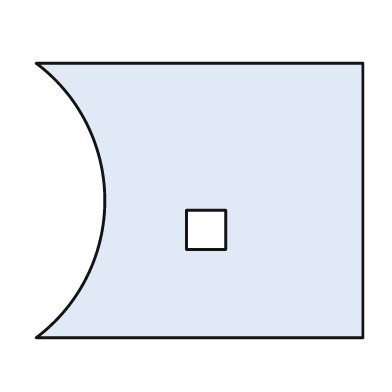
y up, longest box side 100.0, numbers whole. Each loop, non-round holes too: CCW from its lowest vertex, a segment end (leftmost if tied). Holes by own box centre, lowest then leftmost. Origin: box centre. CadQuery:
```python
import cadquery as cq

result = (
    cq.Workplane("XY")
    .moveTo(-50.0, -42.0)
    .lineTo(50.0, -42.0)
    .lineTo(50.0, 42.0)
    .lineTo(-50.0, 42.0)
    .threePointArc((-29.0, 0.0), (-50.0, -42.0))
    .close()
    .moveTo(-4.0, -15.0)
    .lineTo(8.0, -15.0)
    .lineTo(8.0, -3.0)
    .lineTo(-4.0, -3.0)
    .close()
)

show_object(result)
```